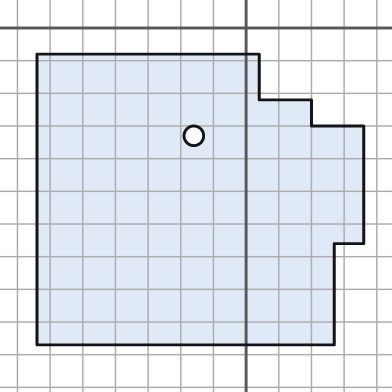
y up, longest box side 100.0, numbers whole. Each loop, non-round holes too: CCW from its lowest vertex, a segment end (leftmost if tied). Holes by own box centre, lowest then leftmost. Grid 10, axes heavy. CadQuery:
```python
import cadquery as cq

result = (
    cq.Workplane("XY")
    .moveTo(-64.0, -97.0)
    .lineTo(27.0, -97.0)
    .lineTo(27.0, -66.0)
    .lineTo(36.0, -66.0)
    .lineTo(36.0, -30.0)
    .lineTo(20.0, -30.0)
    .lineTo(20.0, -22.0)
    .lineTo(4.0, -22.0)
    .lineTo(4.0, -8.0)
    .lineTo(-64.0, -8.0)
    .close()
    .moveTo(-16.0, -33.0)
    .circle(3.0)
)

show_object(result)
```